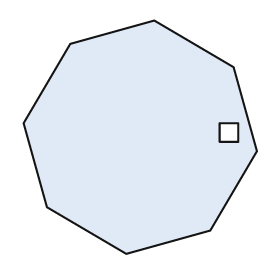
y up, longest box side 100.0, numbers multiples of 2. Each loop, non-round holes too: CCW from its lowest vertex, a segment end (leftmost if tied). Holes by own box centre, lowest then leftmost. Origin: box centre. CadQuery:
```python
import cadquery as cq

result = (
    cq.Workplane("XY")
    .moveTo(-6.0, -50.0)
    .lineTo(30.0, -40.0)
    .lineTo(50.0, -6.0)
    .lineTo(40.0, 30.0)
    .lineTo(6.0, 50.0)
    .lineTo(-30.0, 40.0)
    .lineTo(-50.0, 6.0)
    .lineTo(-40.0, -30.0)
    .close()
    .moveTo(34.0, -2.0)
    .lineTo(42.0, -2.0)
    .lineTo(42.0, 6.0)
    .lineTo(34.0, 6.0)
    .close()
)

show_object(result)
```